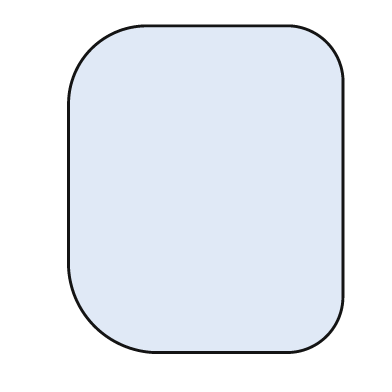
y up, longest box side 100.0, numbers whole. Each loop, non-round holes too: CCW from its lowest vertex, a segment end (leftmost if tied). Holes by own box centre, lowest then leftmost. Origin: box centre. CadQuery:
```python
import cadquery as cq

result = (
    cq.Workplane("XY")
    .moveTo(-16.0, -50.0)
    .lineTo(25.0, -50.0)
    .threePointArc((37.0, -45.0), (42.0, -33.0))
    .lineTo(42.0, 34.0)
    .threePointArc((37.0, 45.0), (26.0, 50.0))
    .lineTo(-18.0, 50.0)
    .threePointArc((-35.0, 43.0), (-42.0, 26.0))
    .lineTo(-42.0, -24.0)
    .threePointArc((-34.0, -42.0), (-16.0, -50.0))
    .close()
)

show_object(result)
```